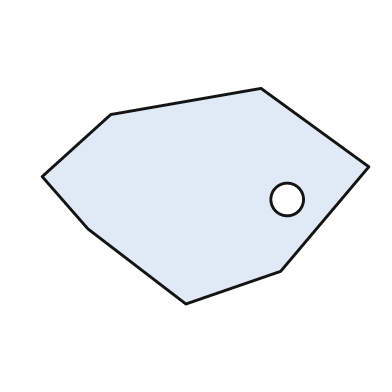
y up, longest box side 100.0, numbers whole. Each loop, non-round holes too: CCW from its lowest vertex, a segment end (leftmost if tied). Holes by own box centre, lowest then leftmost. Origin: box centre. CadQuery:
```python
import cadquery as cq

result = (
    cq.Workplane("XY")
    .moveTo(-6.0, -33.0)
    .lineTo(23.0, -23.0)
    .lineTo(50.0, 9.0)
    .lineTo(17.0, 33.0)
    .lineTo(-29.0, 25.0)
    .lineTo(-50.0, 6.0)
    .lineTo(-36.0, -10.0)
    .close()
    .moveTo(25.0, -1.0)
    .circle(5.0)
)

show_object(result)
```